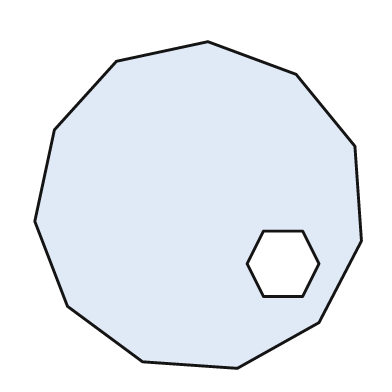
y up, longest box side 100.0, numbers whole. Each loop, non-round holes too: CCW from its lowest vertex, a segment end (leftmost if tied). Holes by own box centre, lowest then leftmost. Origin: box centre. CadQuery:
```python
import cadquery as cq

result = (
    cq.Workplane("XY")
    .moveTo(12.0, -50.0)
    .lineTo(37.0, -36.0)
    .lineTo(50.0, -11.0)
    .lineTo(48.0, 18.0)
    .lineTo(30.0, 40.0)
    .lineTo(3.0, 50.0)
    .lineTo(-25.0, 44.0)
    .lineTo(-44.0, 23.0)
    .lineTo(-50.0, -5.0)
    .lineTo(-40.0, -31.0)
    .lineTo(-17.0, -48.0)
    .close()
    .moveTo(20.0, -28.0)
    .lineTo(32.0, -28.0)
    .lineTo(37.0, -18.0)
    .lineTo(32.0, -8.0)
    .lineTo(20.0, -8.0)
    .lineTo(15.0, -18.0)
    .close()
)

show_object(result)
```